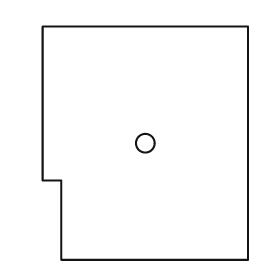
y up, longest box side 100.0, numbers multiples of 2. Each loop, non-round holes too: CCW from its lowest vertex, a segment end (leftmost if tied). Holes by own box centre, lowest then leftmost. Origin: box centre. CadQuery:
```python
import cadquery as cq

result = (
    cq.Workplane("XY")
    .moveTo(-36.0, -50.0)
    .lineTo(44.0, -50.0)
    .lineTo(44.0, 50.0)
    .lineTo(-44.0, 50.0)
    .lineTo(-44.0, -16.0)
    .lineTo(-36.0, -16.0)
    .close()
    .moveTo(0.0, 0.0)
    .circle(4.0)
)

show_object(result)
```